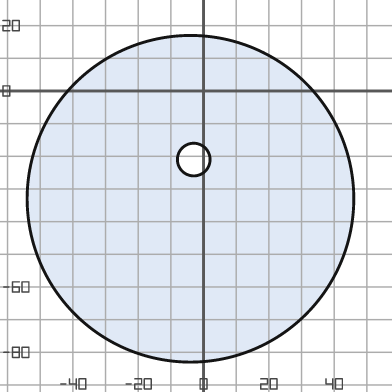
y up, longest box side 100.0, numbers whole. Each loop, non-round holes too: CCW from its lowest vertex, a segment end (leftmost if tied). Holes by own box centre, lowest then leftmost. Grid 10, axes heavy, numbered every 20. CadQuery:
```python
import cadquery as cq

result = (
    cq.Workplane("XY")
    .moveTo(-4.0, -33.0)
    .circle(50.0)
    .moveTo(-3.0, -21.0)
    .circle(5.0)
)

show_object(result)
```